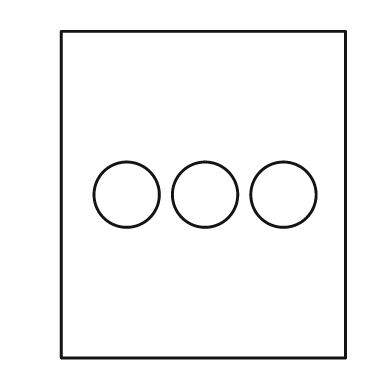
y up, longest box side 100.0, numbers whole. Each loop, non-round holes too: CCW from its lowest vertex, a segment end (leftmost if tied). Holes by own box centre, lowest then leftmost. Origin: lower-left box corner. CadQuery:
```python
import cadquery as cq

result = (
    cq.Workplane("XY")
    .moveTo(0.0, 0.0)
    .lineTo(87.0, 0.0)
    .lineTo(87.0, 100.0)
    .lineTo(0.0, 100.0)
    .close()
    .moveTo(20.0, 50.0)
    .circle(10.0)
    .moveTo(44.0, 50.0)
    .circle(10.0)
    .moveTo(68.0, 50.0)
    .circle(10.0)
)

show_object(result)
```